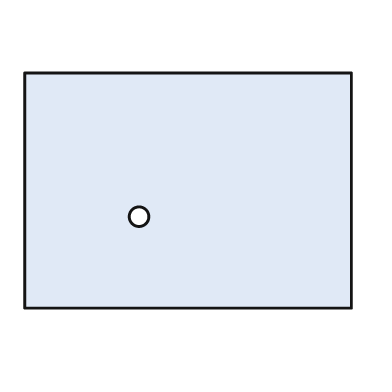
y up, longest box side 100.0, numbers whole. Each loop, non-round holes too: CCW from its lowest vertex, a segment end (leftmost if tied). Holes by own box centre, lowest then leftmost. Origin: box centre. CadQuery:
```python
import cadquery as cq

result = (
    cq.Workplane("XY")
    .moveTo(-50.0, -36.0)
    .lineTo(50.0, -36.0)
    .lineTo(50.0, 36.0)
    .lineTo(-50.0, 36.0)
    .close()
    .moveTo(-15.0, -8.0)
    .circle(3.0)
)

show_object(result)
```